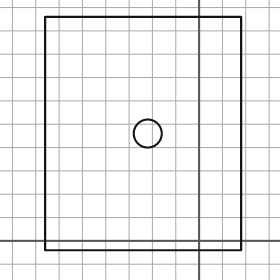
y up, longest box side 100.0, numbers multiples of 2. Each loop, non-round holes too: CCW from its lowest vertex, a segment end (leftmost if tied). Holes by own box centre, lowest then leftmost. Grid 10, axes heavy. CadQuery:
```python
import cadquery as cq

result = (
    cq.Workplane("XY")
    .moveTo(-66.0, -4.0)
    .lineTo(18.0, -4.0)
    .lineTo(18.0, 96.0)
    .lineTo(-66.0, 96.0)
    .close()
    .moveTo(-22.0, 46.0)
    .circle(6.0)
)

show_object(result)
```